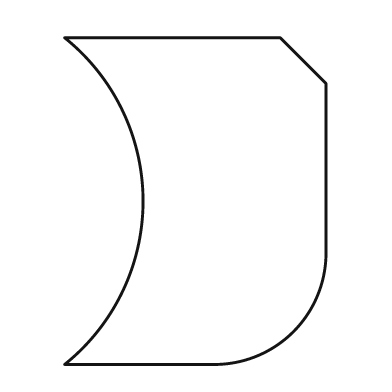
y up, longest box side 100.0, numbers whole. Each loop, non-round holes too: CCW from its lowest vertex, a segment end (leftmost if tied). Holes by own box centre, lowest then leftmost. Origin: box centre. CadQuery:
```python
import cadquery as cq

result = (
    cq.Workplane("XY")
    .moveTo(-40.0, -50.0)
    .lineTo(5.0, -50.0)
    .threePointArc((30.0, -40.0), (40.0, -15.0))
    .lineTo(40.0, 36.0)
    .lineTo(26.0, 50.0)
    .lineTo(-40.0, 50.0)
    .threePointArc((-16.0, 0.0), (-40.0, -50.0))
    .close()
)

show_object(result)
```